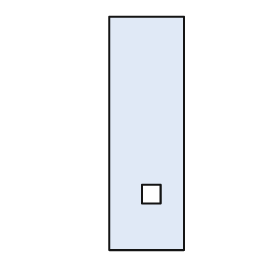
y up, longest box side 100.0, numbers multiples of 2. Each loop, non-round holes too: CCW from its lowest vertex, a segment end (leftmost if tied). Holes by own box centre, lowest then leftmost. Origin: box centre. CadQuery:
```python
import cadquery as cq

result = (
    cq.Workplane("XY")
    .moveTo(-16.0, -50.0)
    .lineTo(16.0, -50.0)
    .lineTo(16.0, 50.0)
    .lineTo(-16.0, 50.0)
    .close()
    .moveTo(-2.0, -30.0)
    .lineTo(6.0, -30.0)
    .lineTo(6.0, -22.0)
    .lineTo(-2.0, -22.0)
    .close()
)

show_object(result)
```